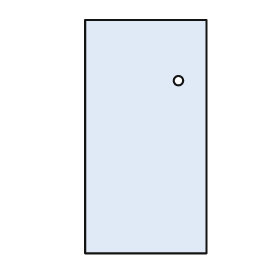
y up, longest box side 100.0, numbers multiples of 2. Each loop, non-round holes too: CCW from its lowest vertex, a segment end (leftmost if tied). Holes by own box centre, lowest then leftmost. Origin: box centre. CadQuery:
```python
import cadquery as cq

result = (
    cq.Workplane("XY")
    .moveTo(-26.0, -50.0)
    .lineTo(26.0, -50.0)
    .lineTo(26.0, 50.0)
    .lineTo(-26.0, 50.0)
    .close()
    .moveTo(14.0, 24.0)
    .circle(2.0)
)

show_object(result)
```